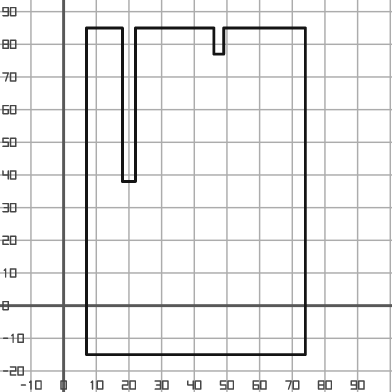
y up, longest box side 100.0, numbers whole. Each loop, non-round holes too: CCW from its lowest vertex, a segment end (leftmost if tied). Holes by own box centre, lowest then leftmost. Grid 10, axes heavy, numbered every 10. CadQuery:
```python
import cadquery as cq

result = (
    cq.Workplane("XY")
    .moveTo(7.0, -15.0)
    .lineTo(74.0, -15.0)
    .lineTo(74.0, 85.0)
    .lineTo(49.0, 85.0)
    .lineTo(49.0, 77.0)
    .lineTo(46.0, 77.0)
    .lineTo(46.0, 85.0)
    .lineTo(22.0, 85.0)
    .lineTo(22.0, 38.0)
    .lineTo(18.0, 38.0)
    .lineTo(18.0, 85.0)
    .lineTo(7.0, 85.0)
    .close()
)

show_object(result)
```